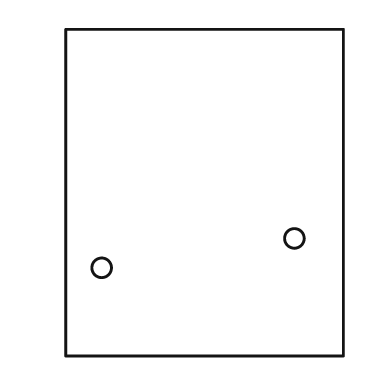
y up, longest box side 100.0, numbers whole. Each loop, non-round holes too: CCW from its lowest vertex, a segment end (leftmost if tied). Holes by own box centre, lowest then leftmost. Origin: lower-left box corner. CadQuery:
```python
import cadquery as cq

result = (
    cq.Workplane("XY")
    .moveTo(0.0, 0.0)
    .lineTo(85.0, 0.0)
    .lineTo(85.0, 100.0)
    .lineTo(0.0, 100.0)
    .close()
    .moveTo(11.0, 27.0)
    .circle(3.0)
    .moveTo(70.0, 36.0)
    .circle(3.0)
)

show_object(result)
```